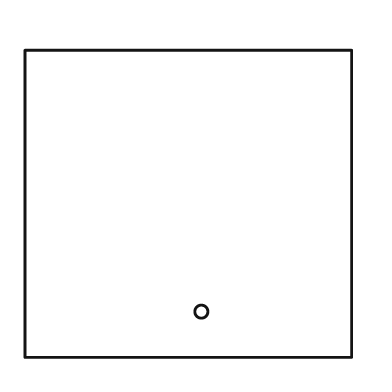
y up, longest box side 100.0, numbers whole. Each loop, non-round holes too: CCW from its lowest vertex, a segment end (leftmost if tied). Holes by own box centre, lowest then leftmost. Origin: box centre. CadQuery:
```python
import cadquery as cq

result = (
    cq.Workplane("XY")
    .moveTo(-50.0, -47.0)
    .lineTo(50.0, -47.0)
    .lineTo(50.0, 47.0)
    .lineTo(-50.0, 47.0)
    .close()
    .moveTo(4.0, -33.0)
    .circle(2.0)
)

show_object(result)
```